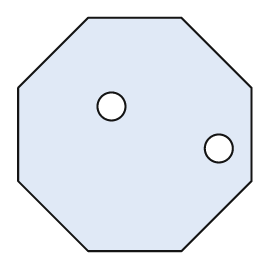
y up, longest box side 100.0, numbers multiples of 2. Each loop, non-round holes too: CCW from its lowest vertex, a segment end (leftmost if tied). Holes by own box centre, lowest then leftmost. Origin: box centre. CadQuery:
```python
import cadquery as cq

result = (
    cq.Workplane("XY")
    .moveTo(-20.0, -50.0)
    .lineTo(20.0, -50.0)
    .lineTo(50.0, -20.0)
    .lineTo(50.0, 20.0)
    .lineTo(20.0, 50.0)
    .lineTo(-20.0, 50.0)
    .lineTo(-50.0, 20.0)
    .lineTo(-50.0, -20.0)
    .close()
    .moveTo(36.0, -6.0)
    .circle(6.0)
    .moveTo(-10.0, 12.0)
    .circle(6.0)
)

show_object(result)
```